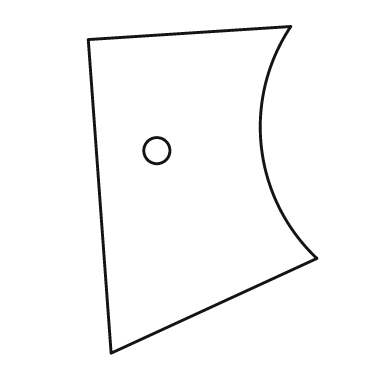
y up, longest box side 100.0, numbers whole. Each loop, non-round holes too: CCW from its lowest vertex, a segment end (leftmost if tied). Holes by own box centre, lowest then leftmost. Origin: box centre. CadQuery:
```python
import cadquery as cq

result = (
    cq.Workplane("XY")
    .moveTo(-28.0, -50.0)
    .lineTo(35.0, -21.0)
    .threePointArc((18.0, 13.0), (27.0, 50.0))
    .lineTo(-35.0, 46.0)
    .close()
    .moveTo(-14.0, 12.0)
    .circle(4.0)
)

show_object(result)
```